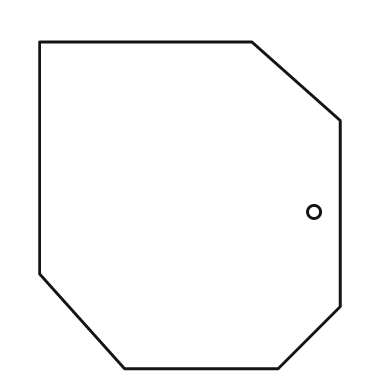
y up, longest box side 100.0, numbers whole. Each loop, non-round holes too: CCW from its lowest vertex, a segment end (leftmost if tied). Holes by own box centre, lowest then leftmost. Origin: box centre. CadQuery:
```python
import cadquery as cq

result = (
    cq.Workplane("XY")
    .moveTo(-20.0, -50.0)
    .lineTo(27.0, -50.0)
    .lineTo(46.0, -31.0)
    .lineTo(46.0, 26.0)
    .lineTo(19.0, 50.0)
    .lineTo(-46.0, 50.0)
    .lineTo(-46.0, -21.0)
    .close()
    .moveTo(38.0, -2.0)
    .circle(2.0)
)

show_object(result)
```